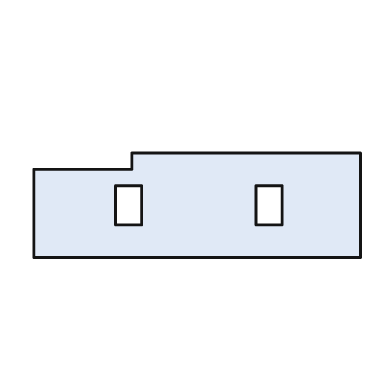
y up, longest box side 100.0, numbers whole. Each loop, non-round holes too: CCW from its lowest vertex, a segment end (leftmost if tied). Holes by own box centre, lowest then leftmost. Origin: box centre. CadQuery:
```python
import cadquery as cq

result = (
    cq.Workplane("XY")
    .moveTo(-50.0, -16.0)
    .lineTo(50.0, -16.0)
    .lineTo(50.0, 16.0)
    .lineTo(-20.0, 16.0)
    .lineTo(-20.0, 11.0)
    .lineTo(-50.0, 11.0)
    .close()
    .moveTo(-25.0, -6.0)
    .lineTo(-17.0, -6.0)
    .lineTo(-17.0, 6.0)
    .lineTo(-25.0, 6.0)
    .close()
    .moveTo(18.0, -6.0)
    .lineTo(26.0, -6.0)
    .lineTo(26.0, 6.0)
    .lineTo(18.0, 6.0)
    .close()
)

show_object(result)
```